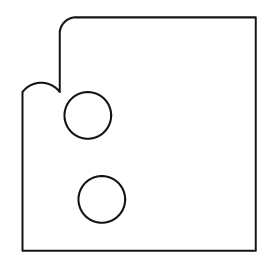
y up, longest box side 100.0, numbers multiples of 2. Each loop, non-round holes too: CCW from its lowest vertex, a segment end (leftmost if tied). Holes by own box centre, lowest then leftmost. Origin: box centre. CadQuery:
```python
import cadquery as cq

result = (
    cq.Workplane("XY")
    .moveTo(-50.0, -50.0)
    .lineTo(50.0, -50.0)
    .lineTo(50.0, 50.0)
    .lineTo(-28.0, 50.0)
    .threePointArc((-32.0, 48.0), (-34.0, 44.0))
    .lineTo(-34.0, 18.0)
    .threePointArc((-42.0, 22.0), (-50.0, 18.0))
    .close()
    .moveTo(-16.0, -28.0)
    .circle(10.0)
    .moveTo(-22.0, 8.0)
    .circle(10.0)
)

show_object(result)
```